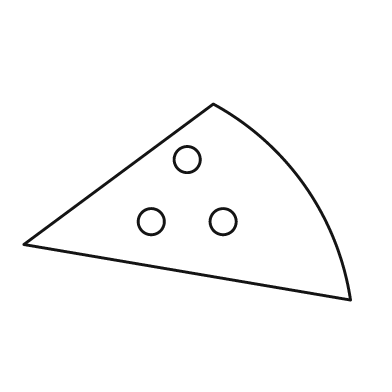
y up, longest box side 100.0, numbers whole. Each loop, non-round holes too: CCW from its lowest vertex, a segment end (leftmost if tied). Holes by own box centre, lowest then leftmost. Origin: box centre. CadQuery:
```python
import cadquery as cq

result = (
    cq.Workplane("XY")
    .moveTo(50.0, -30.0)
    .threePointArc((36.0, 5.0), (8.0, 30.0))
    .lineTo(-50.0, -13.0)
    .close()
    .moveTo(-11.0, -6.0)
    .circle(4.0)
    .moveTo(11.0, -6.0)
    .circle(4.0)
    .moveTo(0.0, 13.0)
    .circle(4.0)
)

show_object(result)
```